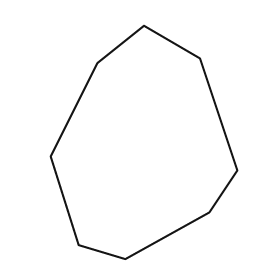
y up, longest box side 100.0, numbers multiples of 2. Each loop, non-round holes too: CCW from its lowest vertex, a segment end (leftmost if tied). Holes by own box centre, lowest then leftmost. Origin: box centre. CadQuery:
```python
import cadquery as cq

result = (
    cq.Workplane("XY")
    .moveTo(-8.0, -50.0)
    .lineTo(28.0, -30.0)
    .lineTo(40.0, -12.0)
    .lineTo(24.0, 36.0)
    .lineTo(0.0, 50.0)
    .lineTo(-20.0, 34.0)
    .lineTo(-40.0, -6.0)
    .lineTo(-28.0, -44.0)
    .close()
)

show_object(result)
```